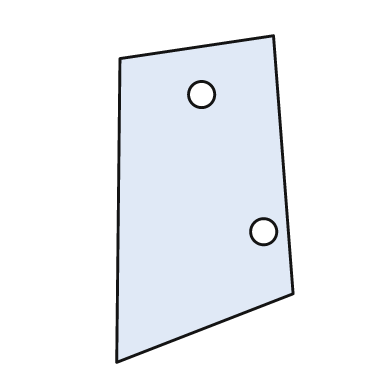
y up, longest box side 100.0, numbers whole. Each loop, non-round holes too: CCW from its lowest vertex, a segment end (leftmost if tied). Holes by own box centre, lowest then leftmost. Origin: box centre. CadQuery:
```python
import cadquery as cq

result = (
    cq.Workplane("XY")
    .moveTo(-27.0, -50.0)
    .lineTo(27.0, -29.0)
    .lineTo(21.0, 50.0)
    .lineTo(-26.0, 43.0)
    .close()
    .moveTo(18.0, -10.0)
    .circle(4.0)
    .moveTo(-1.0, 32.0)
    .circle(4.0)
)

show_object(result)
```